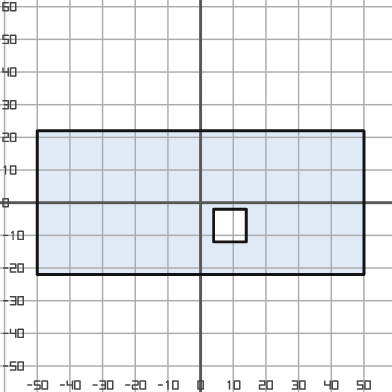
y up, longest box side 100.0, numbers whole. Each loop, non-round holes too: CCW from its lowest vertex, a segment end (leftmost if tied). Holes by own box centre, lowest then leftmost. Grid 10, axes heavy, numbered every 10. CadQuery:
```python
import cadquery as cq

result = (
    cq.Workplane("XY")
    .moveTo(-50.0, -22.0)
    .lineTo(50.0, -22.0)
    .lineTo(50.0, 22.0)
    .lineTo(-50.0, 22.0)
    .close()
    .moveTo(4.0, -12.0)
    .lineTo(14.0, -12.0)
    .lineTo(14.0, -2.0)
    .lineTo(4.0, -2.0)
    .close()
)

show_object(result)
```